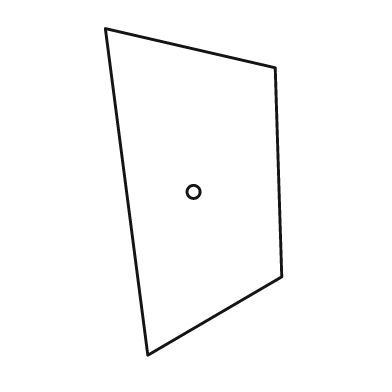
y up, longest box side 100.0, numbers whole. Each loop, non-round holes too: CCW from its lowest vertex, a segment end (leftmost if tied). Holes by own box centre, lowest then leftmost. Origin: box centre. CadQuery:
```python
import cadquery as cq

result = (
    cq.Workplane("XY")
    .moveTo(-14.0, -50.0)
    .lineTo(27.0, -26.0)
    .lineTo(25.0, 38.0)
    .lineTo(-27.0, 50.0)
    .close()
    .moveTo(0.0, 0.0)
    .circle(2.0)
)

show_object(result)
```